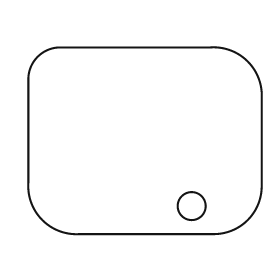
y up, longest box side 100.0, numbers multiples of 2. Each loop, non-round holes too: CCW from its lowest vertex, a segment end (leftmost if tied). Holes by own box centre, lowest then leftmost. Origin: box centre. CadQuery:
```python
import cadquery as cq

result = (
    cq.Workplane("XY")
    .moveTo(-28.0, -40.0)
    .lineTo(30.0, -40.0)
    .threePointArc((44.0, -34.0), (50.0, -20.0))
    .lineTo(50.0, 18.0)
    .threePointArc((44.0, 34.0), (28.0, 40.0))
    .lineTo(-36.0, 40.0)
    .threePointArc((-46.0, 36.0), (-50.0, 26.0))
    .lineTo(-50.0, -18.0)
    .threePointArc((-44.0, -34.0), (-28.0, -40.0))
    .close()
    .moveTo(20.0, -28.0)
    .circle(6.0)
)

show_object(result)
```